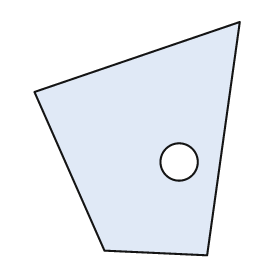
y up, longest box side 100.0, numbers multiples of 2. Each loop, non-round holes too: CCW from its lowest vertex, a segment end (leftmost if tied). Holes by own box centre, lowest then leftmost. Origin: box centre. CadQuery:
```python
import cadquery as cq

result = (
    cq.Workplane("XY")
    .moveTo(30.0, -50.0)
    .lineTo(44.0, 50.0)
    .lineTo(-44.0, 20.0)
    .lineTo(-14.0, -48.0)
    .close()
    .moveTo(18.0, -10.0)
    .circle(8.0)
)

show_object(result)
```